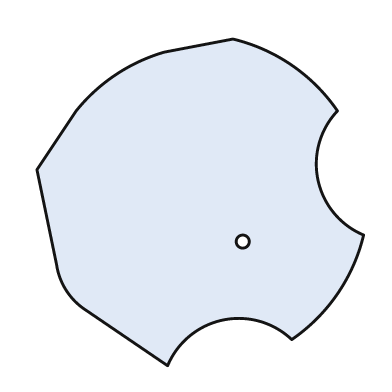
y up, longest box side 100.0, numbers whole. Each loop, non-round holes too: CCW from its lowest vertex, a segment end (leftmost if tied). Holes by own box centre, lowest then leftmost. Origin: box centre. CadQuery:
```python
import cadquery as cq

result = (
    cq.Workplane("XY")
    .moveTo(-10.0, -50.0)
    .threePointArc((7.0, -36.0), (28.0, -42.0))
    .threePointArc((42.0, -28.0), (50.0, -10.0))
    .threePointArc((36.0, 7.0), (42.0, 28.0))
    .threePointArc((28.0, 42.0), (10.0, 50.0))
    .lineTo(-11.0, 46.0)
    .threePointArc((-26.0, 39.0), (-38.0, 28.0))
    .lineTo(-50.0, 10.0)
    .lineTo(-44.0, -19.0)
    .threePointArc((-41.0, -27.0), (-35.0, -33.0))
    .close()
    .moveTo(13.0, -12.0)
    .circle(2.0)
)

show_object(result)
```